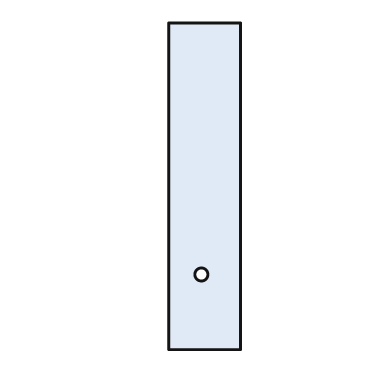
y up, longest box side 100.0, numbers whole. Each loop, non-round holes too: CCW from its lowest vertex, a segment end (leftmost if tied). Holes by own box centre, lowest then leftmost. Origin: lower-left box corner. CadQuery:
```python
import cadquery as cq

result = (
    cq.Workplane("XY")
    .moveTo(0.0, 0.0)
    .lineTo(22.0, 0.0)
    .lineTo(22.0, 100.0)
    .lineTo(0.0, 100.0)
    .close()
    .moveTo(10.0, 23.0)
    .circle(2.0)
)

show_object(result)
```